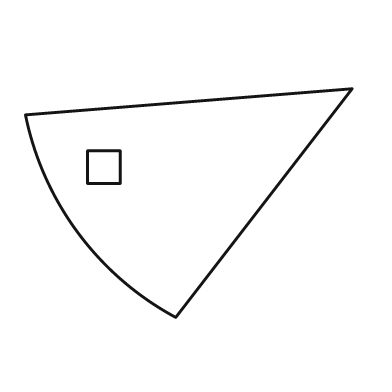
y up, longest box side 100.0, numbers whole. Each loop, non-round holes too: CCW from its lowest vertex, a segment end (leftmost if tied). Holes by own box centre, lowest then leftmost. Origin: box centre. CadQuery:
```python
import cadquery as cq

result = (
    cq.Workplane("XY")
    .moveTo(-4.0, -35.0)
    .lineTo(50.0, 35.0)
    .lineTo(-50.0, 27.0)
    .threePointArc((-34.0, -9.0), (-4.0, -35.0))
    .close()
    .moveTo(-31.0, 6.0)
    .lineTo(-21.0, 6.0)
    .lineTo(-21.0, 16.0)
    .lineTo(-31.0, 16.0)
    .close()
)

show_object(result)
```